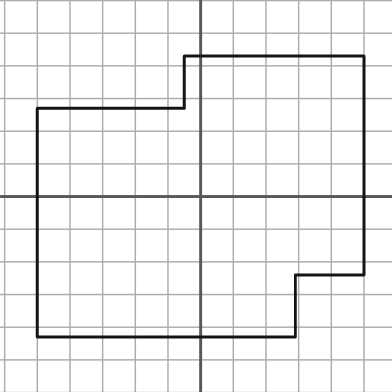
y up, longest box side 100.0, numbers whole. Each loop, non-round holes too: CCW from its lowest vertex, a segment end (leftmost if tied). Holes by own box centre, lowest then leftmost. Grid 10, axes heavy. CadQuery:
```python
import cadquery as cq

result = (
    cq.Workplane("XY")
    .moveTo(-50.0, -43.0)
    .lineTo(29.0, -43.0)
    .lineTo(29.0, -24.0)
    .lineTo(50.0, -24.0)
    .lineTo(50.0, 43.0)
    .lineTo(-5.0, 43.0)
    .lineTo(-5.0, 27.0)
    .lineTo(-50.0, 27.0)
    .close()
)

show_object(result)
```